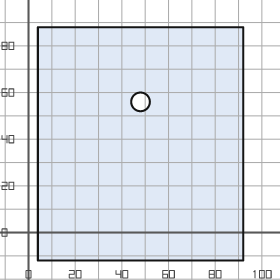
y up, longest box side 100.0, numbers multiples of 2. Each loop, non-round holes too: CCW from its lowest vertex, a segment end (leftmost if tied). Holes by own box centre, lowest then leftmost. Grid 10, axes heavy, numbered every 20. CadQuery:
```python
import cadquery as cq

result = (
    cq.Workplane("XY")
    .moveTo(4.0, -12.0)
    .lineTo(92.0, -12.0)
    .lineTo(92.0, 88.0)
    .lineTo(4.0, 88.0)
    .close()
    .moveTo(48.0, 56.0)
    .circle(4.0)
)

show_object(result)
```